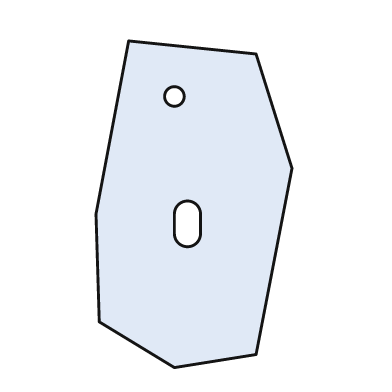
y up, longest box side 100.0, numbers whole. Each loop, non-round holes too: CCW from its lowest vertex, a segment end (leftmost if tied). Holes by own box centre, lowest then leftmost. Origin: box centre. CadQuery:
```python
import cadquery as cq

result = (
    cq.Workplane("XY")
    .moveTo(-6.0, -50.0)
    .lineTo(19.0, -46.0)
    .lineTo(30.0, 11.0)
    .lineTo(19.0, 46.0)
    .lineTo(-20.0, 50.0)
    .lineTo(-30.0, -3.0)
    .lineTo(-29.0, -36.0)
    .close()
    .moveTo(-6.0, -9.0)
    .threePointArc((-2.0, -13.0), (2.0, -9.0))
    .lineTo(2.0, -3.0)
    .threePointArc((-2.0, 1.0), (-6.0, -3.0))
    .close()
    .moveTo(-6.0, 33.0)
    .circle(3.0)
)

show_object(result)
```